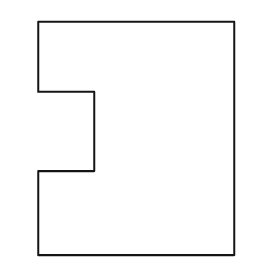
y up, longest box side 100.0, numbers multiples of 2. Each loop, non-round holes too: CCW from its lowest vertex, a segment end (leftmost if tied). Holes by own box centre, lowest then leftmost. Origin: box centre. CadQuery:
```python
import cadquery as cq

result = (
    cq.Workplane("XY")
    .moveTo(-42.0, -50.0)
    .lineTo(42.0, -50.0)
    .lineTo(42.0, 50.0)
    .lineTo(-42.0, 50.0)
    .lineTo(-42.0, 20.0)
    .lineTo(-18.0, 20.0)
    .lineTo(-18.0, -14.0)
    .lineTo(-42.0, -14.0)
    .close()
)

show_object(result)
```